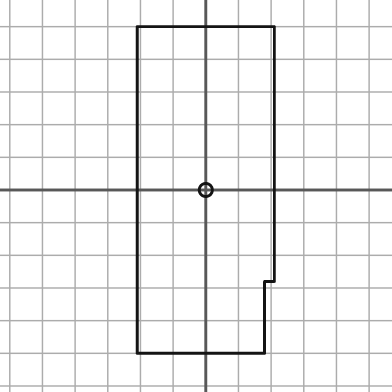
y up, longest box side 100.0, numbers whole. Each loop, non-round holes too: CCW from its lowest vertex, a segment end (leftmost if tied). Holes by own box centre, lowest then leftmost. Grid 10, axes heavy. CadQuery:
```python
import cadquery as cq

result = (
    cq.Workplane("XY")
    .moveTo(-21.0, -50.0)
    .lineTo(18.0, -50.0)
    .lineTo(18.0, -28.0)
    .lineTo(21.0, -28.0)
    .lineTo(21.0, 50.0)
    .lineTo(-21.0, 50.0)
    .close()
    .moveTo(0.0, 0.0)
    .circle(2.0)
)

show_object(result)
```